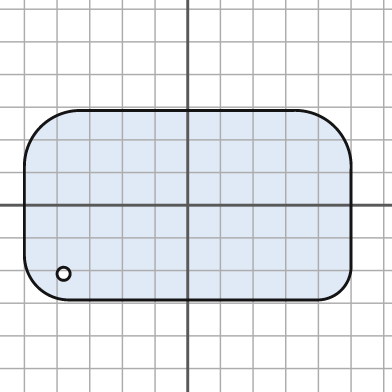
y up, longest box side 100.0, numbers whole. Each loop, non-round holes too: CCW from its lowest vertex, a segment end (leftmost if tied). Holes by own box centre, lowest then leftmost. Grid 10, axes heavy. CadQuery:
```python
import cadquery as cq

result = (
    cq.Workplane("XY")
    .moveTo(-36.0, -29.0)
    .lineTo(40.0, -29.0)
    .threePointArc((47.0, -26.0), (50.0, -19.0))
    .lineTo(50.0, 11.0)
    .threePointArc((45.0, 24.0), (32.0, 29.0))
    .lineTo(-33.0, 29.0)
    .threePointArc((-45.0, 24.0), (-50.0, 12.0))
    .lineTo(-50.0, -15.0)
    .threePointArc((-46.0, -25.0), (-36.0, -29.0))
    .close()
    .moveTo(-38.0, -21.0)
    .circle(2.0)
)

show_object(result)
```